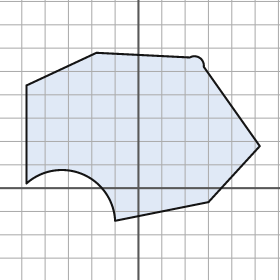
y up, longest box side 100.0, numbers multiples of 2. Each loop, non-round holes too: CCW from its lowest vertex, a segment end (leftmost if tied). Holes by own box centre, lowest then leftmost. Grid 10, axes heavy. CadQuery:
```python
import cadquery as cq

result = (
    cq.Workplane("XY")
    .moveTo(-10.0, -14.0)
    .lineTo(30.0, -6.0)
    .lineTo(52.0, 18.0)
    .lineTo(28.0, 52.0)
    .threePointArc((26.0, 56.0), (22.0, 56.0))
    .lineTo(-18.0, 58.0)
    .lineTo(-48.0, 44.0)
    .lineTo(-48.0, 2.0)
    .threePointArc((-24.0, 6.0), (-10.0, -14.0))
    .close()
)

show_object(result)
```